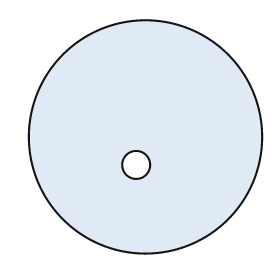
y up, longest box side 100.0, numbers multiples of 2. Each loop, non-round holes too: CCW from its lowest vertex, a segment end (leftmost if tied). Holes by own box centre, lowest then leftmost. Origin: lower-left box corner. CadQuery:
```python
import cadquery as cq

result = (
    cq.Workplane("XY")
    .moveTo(50.0, 50.0)
    .circle(50.0)
    .moveTo(46.0, 38.0)
    .circle(6.0)
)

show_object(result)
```